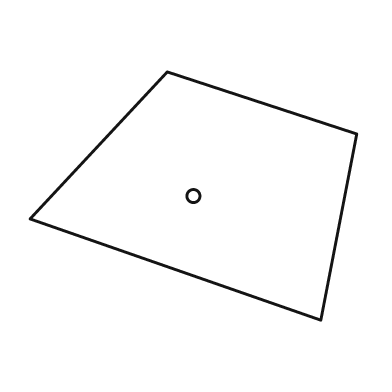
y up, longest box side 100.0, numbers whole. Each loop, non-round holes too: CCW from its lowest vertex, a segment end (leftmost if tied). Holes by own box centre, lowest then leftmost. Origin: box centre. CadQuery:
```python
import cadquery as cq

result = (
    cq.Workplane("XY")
    .moveTo(39.0, -38.0)
    .lineTo(50.0, 19.0)
    .lineTo(-8.0, 38.0)
    .lineTo(-50.0, -7.0)
    .close()
    .moveTo(0.0, 0.0)
    .circle(2.0)
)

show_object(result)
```